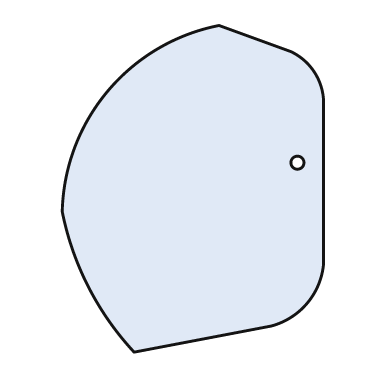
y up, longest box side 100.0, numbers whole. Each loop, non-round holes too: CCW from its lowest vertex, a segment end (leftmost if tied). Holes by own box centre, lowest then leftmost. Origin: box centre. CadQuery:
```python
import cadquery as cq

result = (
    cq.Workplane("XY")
    .moveTo(-18.0, -50.0)
    .lineTo(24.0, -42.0)
    .threePointArc((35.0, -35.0), (40.0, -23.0))
    .lineTo(40.0, 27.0)
    .threePointArc((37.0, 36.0), (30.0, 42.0))
    .lineTo(8.0, 50.0)
    .threePointArc((-26.0, 30.0), (-40.0, -7.0))
    .threePointArc((-32.0, -30.0), (-18.0, -50.0))
    .close()
    .moveTo(32.0, 8.0)
    .circle(2.0)
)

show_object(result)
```